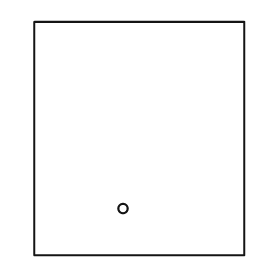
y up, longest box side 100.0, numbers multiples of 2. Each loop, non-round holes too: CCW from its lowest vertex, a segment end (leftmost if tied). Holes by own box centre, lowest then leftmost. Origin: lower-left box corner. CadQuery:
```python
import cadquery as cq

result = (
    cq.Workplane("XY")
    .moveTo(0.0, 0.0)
    .lineTo(90.0, 0.0)
    .lineTo(90.0, 100.0)
    .lineTo(0.0, 100.0)
    .close()
    .moveTo(38.0, 20.0)
    .circle(2.0)
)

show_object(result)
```